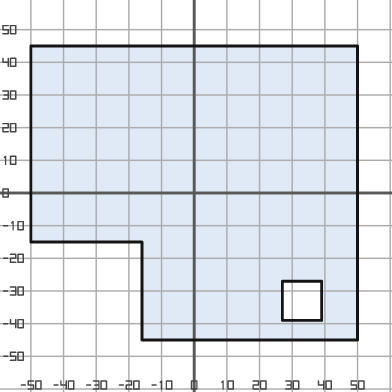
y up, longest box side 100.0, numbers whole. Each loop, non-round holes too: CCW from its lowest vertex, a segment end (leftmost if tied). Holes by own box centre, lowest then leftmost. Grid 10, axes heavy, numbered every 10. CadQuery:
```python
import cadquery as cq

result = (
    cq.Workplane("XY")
    .moveTo(-16.0, -45.0)
    .lineTo(50.0, -45.0)
    .lineTo(50.0, 45.0)
    .lineTo(-50.0, 45.0)
    .lineTo(-50.0, -15.0)
    .lineTo(-16.0, -15.0)
    .close()
    .moveTo(27.0, -39.0)
    .lineTo(39.0, -39.0)
    .lineTo(39.0, -27.0)
    .lineTo(27.0, -27.0)
    .close()
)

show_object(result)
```